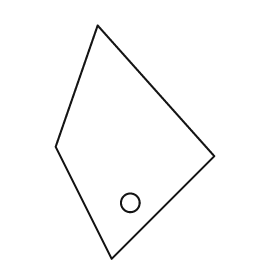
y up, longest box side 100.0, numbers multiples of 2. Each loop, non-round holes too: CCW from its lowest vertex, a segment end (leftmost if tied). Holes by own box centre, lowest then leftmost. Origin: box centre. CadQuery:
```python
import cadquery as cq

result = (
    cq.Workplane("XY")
    .moveTo(-10.0, -50.0)
    .lineTo(34.0, -6.0)
    .lineTo(-16.0, 50.0)
    .lineTo(-34.0, -2.0)
    .close()
    .moveTo(-2.0, -26.0)
    .circle(4.0)
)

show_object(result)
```